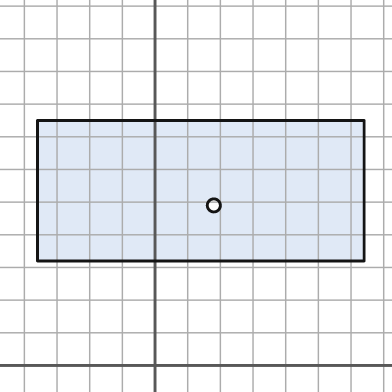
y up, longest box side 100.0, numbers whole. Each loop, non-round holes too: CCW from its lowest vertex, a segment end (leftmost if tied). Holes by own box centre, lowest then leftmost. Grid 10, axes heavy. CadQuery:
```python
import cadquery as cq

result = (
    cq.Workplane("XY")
    .moveTo(-36.0, 32.0)
    .lineTo(64.0, 32.0)
    .lineTo(64.0, 75.0)
    .lineTo(-36.0, 75.0)
    .close()
    .moveTo(18.0, 49.0)
    .circle(2.0)
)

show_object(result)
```